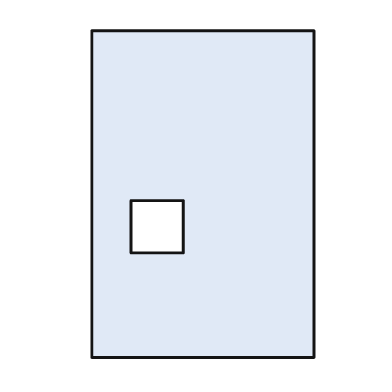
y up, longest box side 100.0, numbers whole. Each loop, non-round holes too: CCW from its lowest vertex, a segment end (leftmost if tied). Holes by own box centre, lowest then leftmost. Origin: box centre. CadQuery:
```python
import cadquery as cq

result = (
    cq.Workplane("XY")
    .moveTo(-34.0, -50.0)
    .lineTo(34.0, -50.0)
    .lineTo(34.0, 50.0)
    .lineTo(-34.0, 50.0)
    .close()
    .moveTo(-22.0, -18.0)
    .lineTo(-6.0, -18.0)
    .lineTo(-6.0, -2.0)
    .lineTo(-22.0, -2.0)
    .close()
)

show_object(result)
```